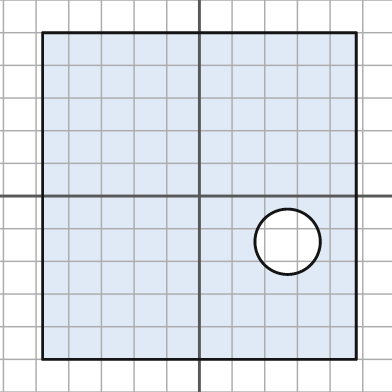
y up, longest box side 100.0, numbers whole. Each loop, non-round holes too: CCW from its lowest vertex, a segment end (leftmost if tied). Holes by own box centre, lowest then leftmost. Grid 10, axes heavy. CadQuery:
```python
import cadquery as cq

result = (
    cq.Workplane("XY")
    .moveTo(-48.0, -50.0)
    .lineTo(48.0, -50.0)
    .lineTo(48.0, 50.0)
    .lineTo(-48.0, 50.0)
    .close()
    .moveTo(27.0, -14.0)
    .circle(10.0)
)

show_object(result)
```